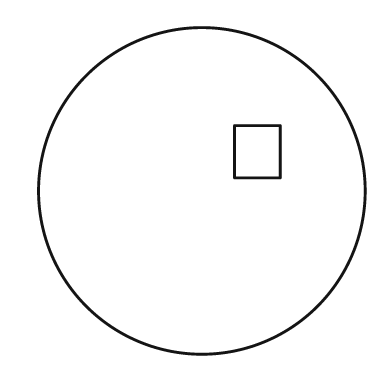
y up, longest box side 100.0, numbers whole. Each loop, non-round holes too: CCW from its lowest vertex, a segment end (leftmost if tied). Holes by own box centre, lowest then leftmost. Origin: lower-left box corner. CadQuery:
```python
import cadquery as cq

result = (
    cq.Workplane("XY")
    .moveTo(50.0, 50.0)
    .circle(50.0)
    .moveTo(60.0, 54.0)
    .lineTo(74.0, 54.0)
    .lineTo(74.0, 70.0)
    .lineTo(60.0, 70.0)
    .close()
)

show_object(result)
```